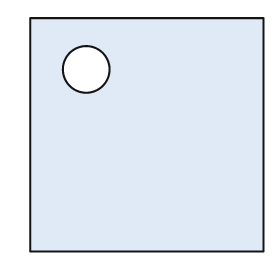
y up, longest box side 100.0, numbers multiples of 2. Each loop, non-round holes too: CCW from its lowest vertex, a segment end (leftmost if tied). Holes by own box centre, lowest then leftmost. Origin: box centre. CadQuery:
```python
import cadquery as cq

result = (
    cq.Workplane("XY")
    .moveTo(-50.0, -50.0)
    .lineTo(50.0, -50.0)
    .lineTo(50.0, 50.0)
    .lineTo(-50.0, 50.0)
    .close()
    .moveTo(-26.0, 28.0)
    .circle(10.0)
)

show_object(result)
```